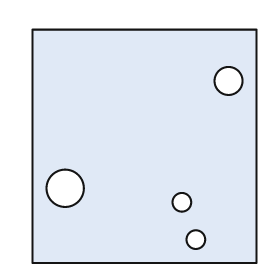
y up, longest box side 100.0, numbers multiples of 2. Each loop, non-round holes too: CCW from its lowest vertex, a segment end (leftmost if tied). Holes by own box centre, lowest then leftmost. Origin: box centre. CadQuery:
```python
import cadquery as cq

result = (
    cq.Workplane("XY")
    .moveTo(-48.0, -50.0)
    .lineTo(48.0, -50.0)
    .lineTo(48.0, 50.0)
    .lineTo(-48.0, 50.0)
    .close()
    .moveTo(22.0, -40.0)
    .circle(4.0)
    .moveTo(16.0, -24.0)
    .circle(4.0)
    .moveTo(-34.0, -18.0)
    .circle(8.0)
    .moveTo(36.0, 28.0)
    .circle(6.0)
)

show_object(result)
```